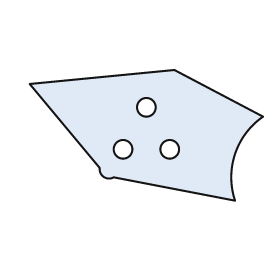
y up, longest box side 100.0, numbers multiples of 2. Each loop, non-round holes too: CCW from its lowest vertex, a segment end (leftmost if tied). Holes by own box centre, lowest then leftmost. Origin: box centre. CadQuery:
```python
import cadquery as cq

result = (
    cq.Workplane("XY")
    .moveTo(38.0, -28.0)
    .threePointArc((38.0, -8.0), (50.0, 8.0))
    .lineTo(12.0, 28.0)
    .lineTo(-50.0, 22.0)
    .lineTo(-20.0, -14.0)
    .threePointArc((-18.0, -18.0), (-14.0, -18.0))
    .close()
    .moveTo(-10.0, -6.0)
    .circle(4.0)
    .moveTo(10.0, -6.0)
    .circle(4.0)
    .moveTo(0.0, 12.0)
    .circle(4.0)
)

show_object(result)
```